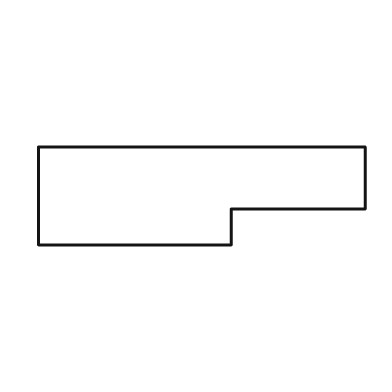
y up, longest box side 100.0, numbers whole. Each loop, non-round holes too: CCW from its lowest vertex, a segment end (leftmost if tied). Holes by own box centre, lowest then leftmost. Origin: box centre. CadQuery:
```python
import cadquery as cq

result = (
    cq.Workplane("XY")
    .moveTo(-50.0, -15.0)
    .lineTo(9.0, -15.0)
    .lineTo(9.0, -4.0)
    .lineTo(50.0, -4.0)
    .lineTo(50.0, 15.0)
    .lineTo(-50.0, 15.0)
    .close()
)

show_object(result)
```